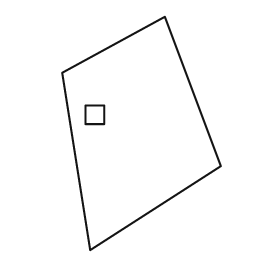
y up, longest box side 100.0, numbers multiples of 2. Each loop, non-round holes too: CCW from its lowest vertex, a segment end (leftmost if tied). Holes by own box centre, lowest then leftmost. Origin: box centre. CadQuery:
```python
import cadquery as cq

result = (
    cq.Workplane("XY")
    .moveTo(-22.0, -50.0)
    .lineTo(34.0, -14.0)
    .lineTo(10.0, 50.0)
    .lineTo(-34.0, 26.0)
    .close()
    .moveTo(-24.0, 4.0)
    .lineTo(-16.0, 4.0)
    .lineTo(-16.0, 12.0)
    .lineTo(-24.0, 12.0)
    .close()
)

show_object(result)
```